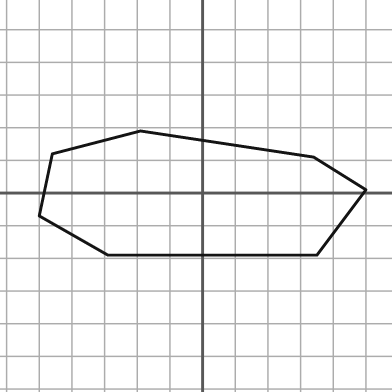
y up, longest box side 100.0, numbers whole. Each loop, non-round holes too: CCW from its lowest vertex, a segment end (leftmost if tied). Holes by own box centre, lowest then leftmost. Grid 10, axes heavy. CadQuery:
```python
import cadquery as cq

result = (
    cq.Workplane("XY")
    .moveTo(-29.0, -19.0)
    .lineTo(35.0, -19.0)
    .lineTo(50.0, 1.0)
    .lineTo(34.0, 11.0)
    .lineTo(-19.0, 19.0)
    .lineTo(-46.0, 12.0)
    .lineTo(-50.0, -7.0)
    .close()
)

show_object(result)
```